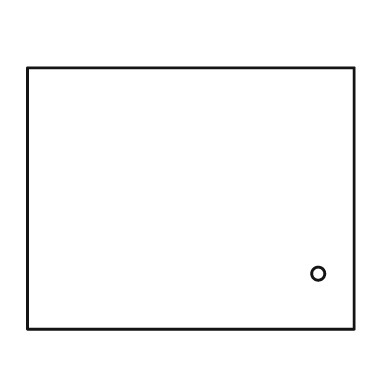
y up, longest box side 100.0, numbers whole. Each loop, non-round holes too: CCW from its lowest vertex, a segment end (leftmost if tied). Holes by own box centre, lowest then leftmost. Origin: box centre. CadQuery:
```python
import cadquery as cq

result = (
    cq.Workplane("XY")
    .moveTo(-50.0, -40.0)
    .lineTo(50.0, -40.0)
    .lineTo(50.0, 40.0)
    .lineTo(-50.0, 40.0)
    .close()
    .moveTo(39.0, -23.0)
    .circle(2.0)
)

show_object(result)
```